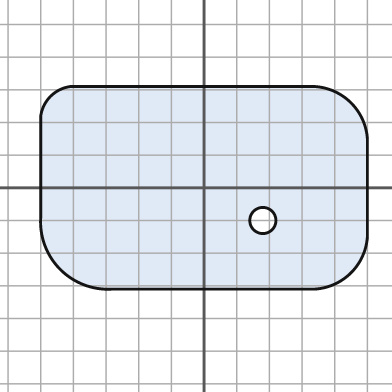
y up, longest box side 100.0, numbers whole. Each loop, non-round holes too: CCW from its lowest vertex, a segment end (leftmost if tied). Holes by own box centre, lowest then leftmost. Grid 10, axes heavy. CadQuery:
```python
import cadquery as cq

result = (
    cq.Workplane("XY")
    .moveTo(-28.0, -31.0)
    .lineTo(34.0, -31.0)
    .threePointArc((45.0, -26.0), (50.0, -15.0))
    .lineTo(50.0, 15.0)
    .threePointArc((45.0, 26.0), (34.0, 31.0))
    .lineTo(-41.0, 31.0)
    .threePointArc((-47.0, 28.0), (-50.0, 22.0))
    .lineTo(-50.0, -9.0)
    .threePointArc((-44.0, -25.0), (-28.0, -31.0))
    .close()
    .moveTo(18.0, -10.0)
    .circle(4.0)
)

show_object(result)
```